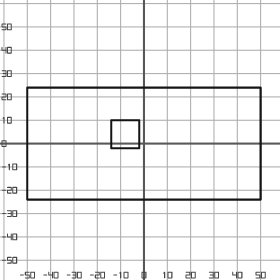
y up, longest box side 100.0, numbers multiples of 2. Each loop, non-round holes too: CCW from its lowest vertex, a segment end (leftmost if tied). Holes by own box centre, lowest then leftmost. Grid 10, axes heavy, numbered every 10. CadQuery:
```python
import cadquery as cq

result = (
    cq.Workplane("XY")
    .moveTo(-50.0, -24.0)
    .lineTo(50.0, -24.0)
    .lineTo(50.0, 24.0)
    .lineTo(-50.0, 24.0)
    .close()
    .moveTo(-14.0, -2.0)
    .lineTo(-2.0, -2.0)
    .lineTo(-2.0, 10.0)
    .lineTo(-14.0, 10.0)
    .close()
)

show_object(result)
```